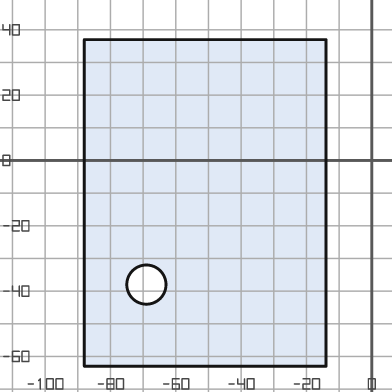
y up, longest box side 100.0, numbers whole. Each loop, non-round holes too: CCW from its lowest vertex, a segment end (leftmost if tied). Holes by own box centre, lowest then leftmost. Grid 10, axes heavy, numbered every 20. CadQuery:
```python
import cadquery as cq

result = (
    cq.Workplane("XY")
    .moveTo(-88.0, -63.0)
    .lineTo(-14.0, -63.0)
    .lineTo(-14.0, 37.0)
    .lineTo(-88.0, 37.0)
    .close()
    .moveTo(-69.0, -38.0)
    .circle(6.0)
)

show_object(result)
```